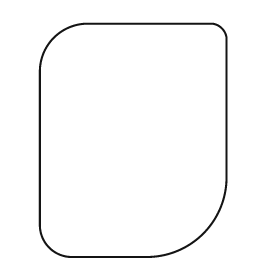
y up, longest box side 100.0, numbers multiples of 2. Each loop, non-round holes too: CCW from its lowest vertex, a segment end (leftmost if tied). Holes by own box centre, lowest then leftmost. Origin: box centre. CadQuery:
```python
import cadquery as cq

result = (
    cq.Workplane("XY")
    .moveTo(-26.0, -50.0)
    .lineTo(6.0, -50.0)
    .threePointArc((30.0, -40.0), (40.0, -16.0))
    .lineTo(40.0, 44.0)
    .threePointArc((38.0, 48.0), (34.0, 50.0))
    .lineTo(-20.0, 50.0)
    .threePointArc((-34.0, 44.0), (-40.0, 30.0))
    .lineTo(-40.0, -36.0)
    .threePointArc((-36.0, -46.0), (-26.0, -50.0))
    .close()
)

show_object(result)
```